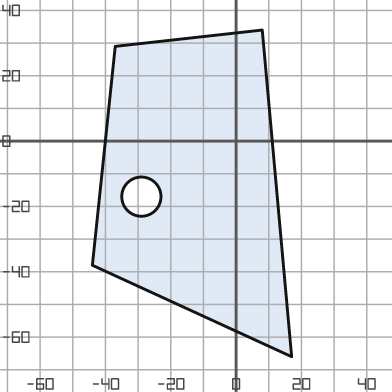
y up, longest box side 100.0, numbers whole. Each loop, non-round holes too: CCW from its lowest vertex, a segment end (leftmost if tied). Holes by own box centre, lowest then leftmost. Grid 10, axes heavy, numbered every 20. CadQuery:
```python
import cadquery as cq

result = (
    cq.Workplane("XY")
    .moveTo(17.0, -66.0)
    .lineTo(8.0, 34.0)
    .lineTo(-37.0, 29.0)
    .lineTo(-44.0, -38.0)
    .close()
    .moveTo(-29.0, -17.0)
    .circle(6.0)
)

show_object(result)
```